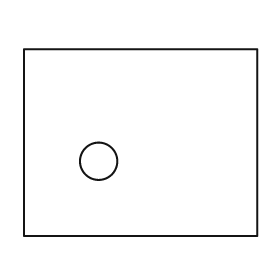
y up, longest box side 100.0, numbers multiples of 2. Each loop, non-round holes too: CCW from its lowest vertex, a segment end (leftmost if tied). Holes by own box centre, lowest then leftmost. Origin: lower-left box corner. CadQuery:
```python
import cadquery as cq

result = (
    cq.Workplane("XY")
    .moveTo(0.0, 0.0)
    .lineTo(100.0, 0.0)
    .lineTo(100.0, 80.0)
    .lineTo(0.0, 80.0)
    .close()
    .moveTo(32.0, 32.0)
    .circle(8.0)
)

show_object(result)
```